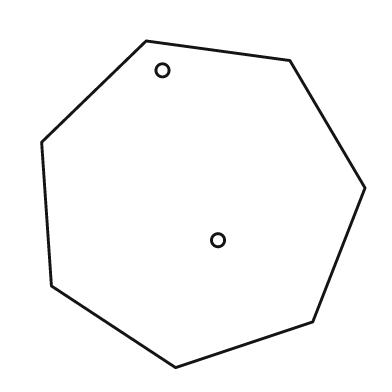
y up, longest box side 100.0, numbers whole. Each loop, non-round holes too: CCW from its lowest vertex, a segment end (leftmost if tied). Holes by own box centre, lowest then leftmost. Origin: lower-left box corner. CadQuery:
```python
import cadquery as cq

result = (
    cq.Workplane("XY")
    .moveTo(41.0, 0.0)
    .lineTo(83.0, 14.0)
    .lineTo(99.0, 55.0)
    .lineTo(76.0, 94.0)
    .lineTo(32.0, 100.0)
    .lineTo(0.0, 69.0)
    .lineTo(3.0, 25.0)
    .close()
    .moveTo(54.0, 39.0)
    .circle(2.0)
    .moveTo(37.0, 91.0)
    .circle(2.0)
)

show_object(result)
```